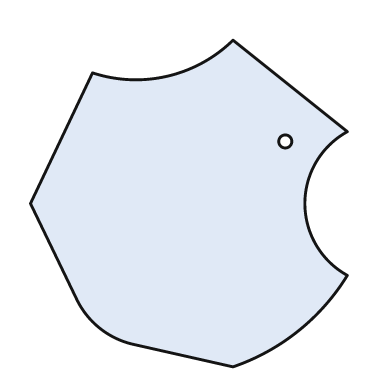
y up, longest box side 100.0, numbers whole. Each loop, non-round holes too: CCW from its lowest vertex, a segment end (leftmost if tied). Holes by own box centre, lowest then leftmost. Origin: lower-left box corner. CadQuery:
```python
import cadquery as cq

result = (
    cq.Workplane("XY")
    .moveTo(62.0, 0.0)
    .threePointArc((82.0, 11.0), (97.0, 28.0))
    .threePointArc((84.0, 50.0), (97.0, 72.0))
    .lineTo(62.0, 100.0)
    .threePointArc((42.0, 89.0), (19.0, 90.0))
    .lineTo(0.0, 50.0)
    .lineTo(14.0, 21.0)
    .threePointArc((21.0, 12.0), (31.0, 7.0))
    .close()
    .moveTo(78.0, 69.0)
    .circle(2.0)
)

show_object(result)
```